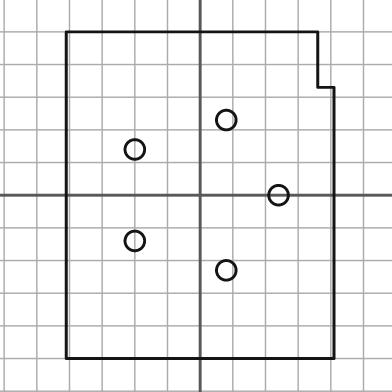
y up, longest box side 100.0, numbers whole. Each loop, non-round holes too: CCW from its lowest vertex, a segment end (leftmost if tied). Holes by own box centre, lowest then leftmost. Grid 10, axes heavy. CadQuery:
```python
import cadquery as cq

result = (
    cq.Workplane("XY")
    .moveTo(-41.0, -50.0)
    .lineTo(41.0, -50.0)
    .lineTo(41.0, 33.0)
    .lineTo(36.0, 33.0)
    .lineTo(36.0, 50.0)
    .lineTo(-41.0, 50.0)
    .close()
    .moveTo(8.0, -23.0)
    .circle(3.0)
    .moveTo(-20.0, -14.0)
    .circle(3.0)
    .moveTo(24.0, 0.0)
    .circle(3.0)
    .moveTo(-20.0, 14.0)
    .circle(3.0)
    .moveTo(8.0, 23.0)
    .circle(3.0)
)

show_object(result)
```